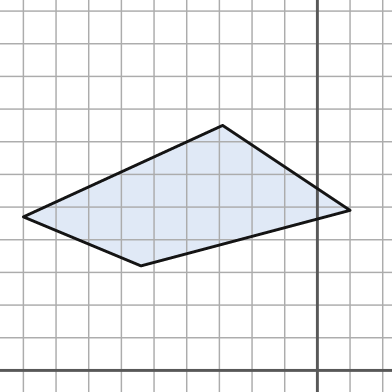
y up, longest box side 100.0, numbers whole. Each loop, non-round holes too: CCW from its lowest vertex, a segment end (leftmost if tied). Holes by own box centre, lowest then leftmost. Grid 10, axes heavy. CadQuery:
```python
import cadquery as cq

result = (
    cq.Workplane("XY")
    .moveTo(-54.0, 32.0)
    .lineTo(10.0, 49.0)
    .lineTo(-29.0, 75.0)
    .lineTo(-90.0, 47.0)
    .close()
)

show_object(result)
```